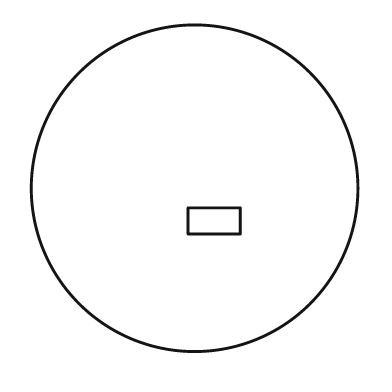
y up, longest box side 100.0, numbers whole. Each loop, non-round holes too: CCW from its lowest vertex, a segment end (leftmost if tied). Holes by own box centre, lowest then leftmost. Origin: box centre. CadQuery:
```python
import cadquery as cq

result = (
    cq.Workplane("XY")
    .moveTo(0.0, 0.0)
    .circle(50.0)
    .moveTo(-2.0, -14.0)
    .lineTo(14.0, -14.0)
    .lineTo(14.0, -6.0)
    .lineTo(-2.0, -6.0)
    .close()
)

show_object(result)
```